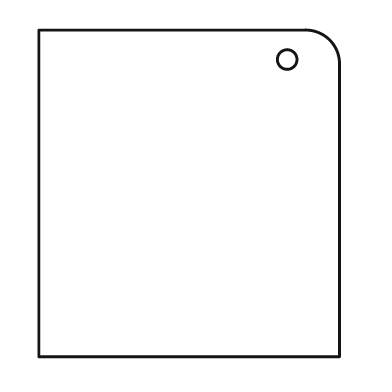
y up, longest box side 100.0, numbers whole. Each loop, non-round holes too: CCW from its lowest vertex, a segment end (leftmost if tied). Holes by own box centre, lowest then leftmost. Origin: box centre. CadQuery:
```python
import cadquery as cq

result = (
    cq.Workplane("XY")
    .moveTo(-46.0, -50.0)
    .lineTo(46.0, -50.0)
    .lineTo(46.0, 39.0)
    .threePointArc((43.0, 47.0), (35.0, 50.0))
    .lineTo(-46.0, 50.0)
    .close()
    .moveTo(30.0, 41.0)
    .circle(3.0)
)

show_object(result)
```